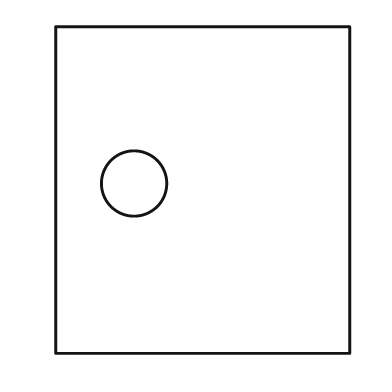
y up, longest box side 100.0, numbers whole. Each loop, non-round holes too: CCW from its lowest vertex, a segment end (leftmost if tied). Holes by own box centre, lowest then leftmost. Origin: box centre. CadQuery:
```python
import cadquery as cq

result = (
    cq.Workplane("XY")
    .moveTo(-45.0, -50.0)
    .lineTo(45.0, -50.0)
    .lineTo(45.0, 50.0)
    .lineTo(-45.0, 50.0)
    .close()
    .moveTo(-21.0, 2.0)
    .circle(10.0)
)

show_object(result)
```